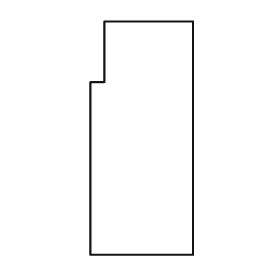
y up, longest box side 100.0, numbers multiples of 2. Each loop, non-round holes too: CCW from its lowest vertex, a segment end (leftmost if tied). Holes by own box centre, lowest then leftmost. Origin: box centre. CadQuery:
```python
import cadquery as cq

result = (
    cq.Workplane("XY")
    .moveTo(-22.0, -50.0)
    .lineTo(22.0, -50.0)
    .lineTo(22.0, 50.0)
    .lineTo(-16.0, 50.0)
    .lineTo(-16.0, 24.0)
    .lineTo(-22.0, 24.0)
    .close()
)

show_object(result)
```